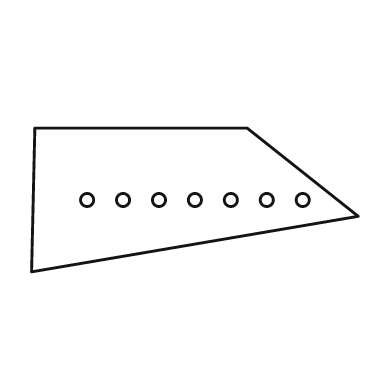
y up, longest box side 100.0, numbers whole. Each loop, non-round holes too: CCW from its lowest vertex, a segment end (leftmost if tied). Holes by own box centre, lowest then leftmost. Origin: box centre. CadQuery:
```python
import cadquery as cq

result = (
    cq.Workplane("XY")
    .moveTo(-50.0, -22.0)
    .lineTo(50.0, -5.0)
    .lineTo(16.0, 22.0)
    .lineTo(-49.0, 22.0)
    .close()
    .moveTo(-33.0, 0.0)
    .circle(2.0)
    .moveTo(-22.0, 0.0)
    .circle(2.0)
    .moveTo(-11.0, 0.0)
    .circle(2.0)
    .moveTo(0.0, 0.0)
    .circle(2.0)
    .moveTo(11.0, 0.0)
    .circle(2.0)
    .moveTo(22.0, 0.0)
    .circle(2.0)
    .moveTo(33.0, 0.0)
    .circle(2.0)
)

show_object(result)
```